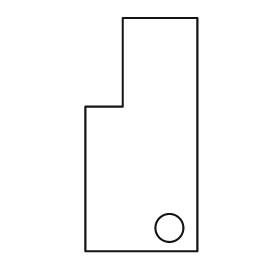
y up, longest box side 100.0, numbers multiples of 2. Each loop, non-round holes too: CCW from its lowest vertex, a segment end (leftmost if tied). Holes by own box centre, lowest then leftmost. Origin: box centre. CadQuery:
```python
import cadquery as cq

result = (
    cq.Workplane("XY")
    .moveTo(-24.0, -50.0)
    .lineTo(24.0, -50.0)
    .lineTo(24.0, 50.0)
    .lineTo(-8.0, 50.0)
    .lineTo(-8.0, 12.0)
    .lineTo(-24.0, 12.0)
    .close()
    .moveTo(12.0, -40.0)
    .circle(6.0)
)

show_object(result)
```